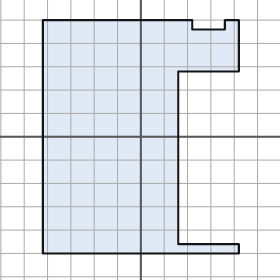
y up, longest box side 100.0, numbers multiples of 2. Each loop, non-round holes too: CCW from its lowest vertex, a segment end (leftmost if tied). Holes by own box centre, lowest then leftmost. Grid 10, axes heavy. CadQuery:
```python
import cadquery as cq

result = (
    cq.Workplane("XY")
    .moveTo(-42.0, -50.0)
    .lineTo(42.0, -50.0)
    .lineTo(42.0, -46.0)
    .lineTo(16.0, -46.0)
    .lineTo(16.0, 28.0)
    .lineTo(42.0, 28.0)
    .lineTo(42.0, 50.0)
    .lineTo(36.0, 50.0)
    .lineTo(36.0, 46.0)
    .lineTo(22.0, 46.0)
    .lineTo(22.0, 50.0)
    .lineTo(-42.0, 50.0)
    .close()
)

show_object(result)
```